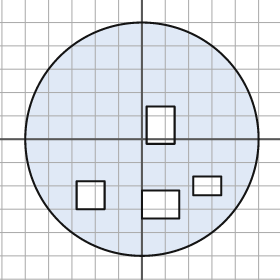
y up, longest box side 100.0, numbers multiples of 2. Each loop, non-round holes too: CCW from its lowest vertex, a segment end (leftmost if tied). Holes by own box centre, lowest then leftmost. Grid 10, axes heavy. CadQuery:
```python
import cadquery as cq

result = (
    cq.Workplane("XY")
    .moveTo(0.0, 0.0)
    .circle(50.0)
    .moveTo(0.0, -34.0)
    .lineTo(16.0, -34.0)
    .lineTo(16.0, -22.0)
    .lineTo(0.0, -22.0)
    .close()
    .moveTo(-28.0, -30.0)
    .lineTo(-16.0, -30.0)
    .lineTo(-16.0, -18.0)
    .lineTo(-28.0, -18.0)
    .close()
    .moveTo(22.0, -24.0)
    .lineTo(34.0, -24.0)
    .lineTo(34.0, -16.0)
    .lineTo(22.0, -16.0)
    .close()
    .moveTo(2.0, -2.0)
    .lineTo(14.0, -2.0)
    .lineTo(14.0, 14.0)
    .lineTo(2.0, 14.0)
    .close()
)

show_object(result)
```